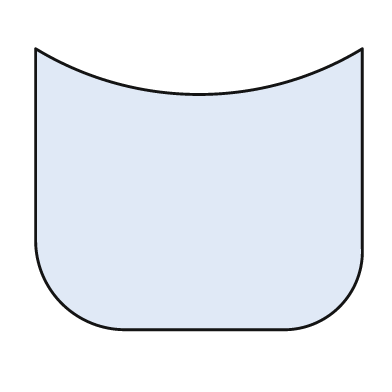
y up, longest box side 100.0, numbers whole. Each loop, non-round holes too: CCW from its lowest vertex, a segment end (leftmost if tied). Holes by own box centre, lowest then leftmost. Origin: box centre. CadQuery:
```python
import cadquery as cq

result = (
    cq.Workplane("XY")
    .moveTo(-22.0, -43.0)
    .lineTo(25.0, -43.0)
    .threePointArc((43.0, -36.0), (50.0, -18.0))
    .lineTo(50.0, 43.0)
    .threePointArc((0.0, 29.0), (-50.0, 43.0))
    .lineTo(-50.0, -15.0)
    .threePointArc((-42.0, -35.0), (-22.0, -43.0))
    .close()
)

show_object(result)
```